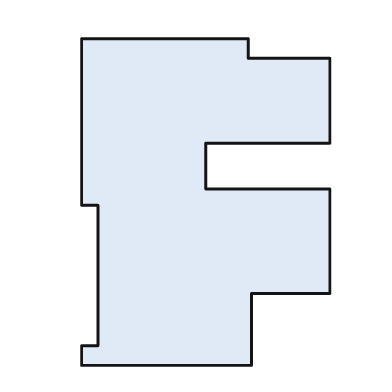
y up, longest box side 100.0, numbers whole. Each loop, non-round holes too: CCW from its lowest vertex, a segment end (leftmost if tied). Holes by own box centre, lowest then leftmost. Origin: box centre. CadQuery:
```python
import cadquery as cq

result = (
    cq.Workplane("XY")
    .moveTo(-38.0, -50.0)
    .lineTo(14.0, -50.0)
    .lineTo(14.0, -28.0)
    .lineTo(38.0, -28.0)
    .lineTo(38.0, 4.0)
    .lineTo(0.0, 4.0)
    .lineTo(0.0, 18.0)
    .lineTo(38.0, 18.0)
    .lineTo(38.0, 44.0)
    .lineTo(13.0, 44.0)
    .lineTo(13.0, 50.0)
    .lineTo(-38.0, 50.0)
    .lineTo(-38.0, -1.0)
    .lineTo(-33.0, -1.0)
    .lineTo(-33.0, -44.0)
    .lineTo(-38.0, -44.0)
    .close()
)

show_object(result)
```